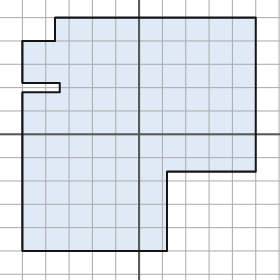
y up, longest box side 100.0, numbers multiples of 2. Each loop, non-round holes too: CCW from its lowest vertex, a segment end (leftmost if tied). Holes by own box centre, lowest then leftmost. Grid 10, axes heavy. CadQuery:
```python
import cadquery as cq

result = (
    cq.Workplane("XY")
    .moveTo(-50.0, -50.0)
    .lineTo(12.0, -50.0)
    .lineTo(12.0, -16.0)
    .lineTo(50.0, -16.0)
    .lineTo(50.0, 50.0)
    .lineTo(-36.0, 50.0)
    .lineTo(-36.0, 40.0)
    .lineTo(-50.0, 40.0)
    .lineTo(-50.0, 22.0)
    .lineTo(-34.0, 22.0)
    .lineTo(-34.0, 18.0)
    .lineTo(-50.0, 18.0)
    .close()
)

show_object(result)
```